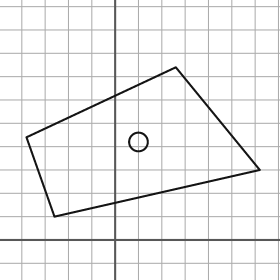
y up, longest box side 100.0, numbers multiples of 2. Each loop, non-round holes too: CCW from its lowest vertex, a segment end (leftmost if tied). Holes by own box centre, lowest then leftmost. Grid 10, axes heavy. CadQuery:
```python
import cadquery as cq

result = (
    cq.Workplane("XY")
    .moveTo(-26.0, 10.0)
    .lineTo(62.0, 30.0)
    .lineTo(26.0, 74.0)
    .lineTo(-38.0, 44.0)
    .close()
    .moveTo(10.0, 42.0)
    .circle(4.0)
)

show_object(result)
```